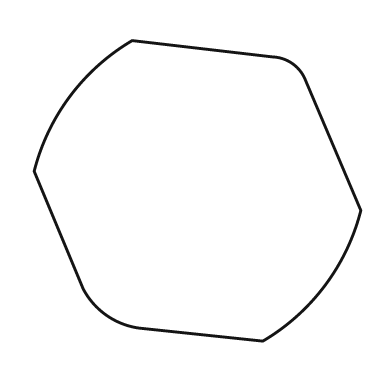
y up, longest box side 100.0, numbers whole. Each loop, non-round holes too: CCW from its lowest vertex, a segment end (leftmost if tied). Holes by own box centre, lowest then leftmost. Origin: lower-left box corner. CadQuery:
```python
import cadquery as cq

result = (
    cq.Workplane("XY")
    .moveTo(70.0, 0.0)
    .threePointArc((89.0, 17.0), (100.0, 40.0))
    .lineTo(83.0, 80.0)
    .threePointArc((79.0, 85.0), (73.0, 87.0))
    .lineTo(30.0, 92.0)
    .threePointArc((11.0, 75.0), (0.0, 52.0))
    .lineTo(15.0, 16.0)
    .threePointArc((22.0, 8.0), (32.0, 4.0))
    .close()
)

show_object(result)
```